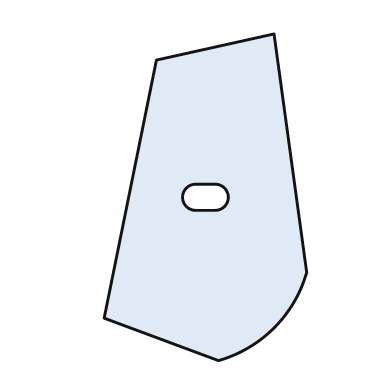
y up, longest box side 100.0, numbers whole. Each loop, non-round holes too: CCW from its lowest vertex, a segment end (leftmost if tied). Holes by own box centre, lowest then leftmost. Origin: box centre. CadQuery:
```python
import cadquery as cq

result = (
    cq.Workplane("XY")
    .moveTo(4.0, -50.0)
    .threePointArc((21.0, -40.0), (31.0, -23.0))
    .lineTo(21.0, 50.0)
    .lineTo(-15.0, 42.0)
    .lineTo(-31.0, -37.0)
    .close()
    .moveTo(-3.0, -4.0)
    .lineTo(3.0, -4.0)
    .threePointArc((7.0, 0.0), (3.0, 4.0))
    .lineTo(-3.0, 4.0)
    .threePointArc((-7.0, 0.0), (-3.0, -4.0))
    .close()
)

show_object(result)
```